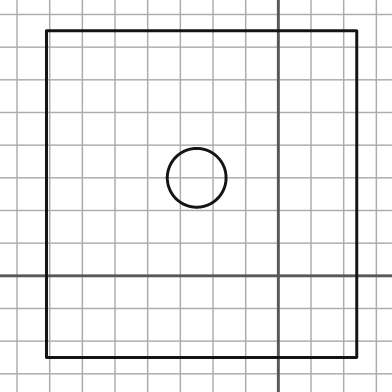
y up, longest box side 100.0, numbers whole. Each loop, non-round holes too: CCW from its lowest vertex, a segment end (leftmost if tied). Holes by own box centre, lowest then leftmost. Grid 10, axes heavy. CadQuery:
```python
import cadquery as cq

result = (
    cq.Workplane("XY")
    .moveTo(-71.0, -25.0)
    .lineTo(24.0, -25.0)
    .lineTo(24.0, 75.0)
    .lineTo(-71.0, 75.0)
    .close()
    .moveTo(-25.0, 30.0)
    .circle(9.0)
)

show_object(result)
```